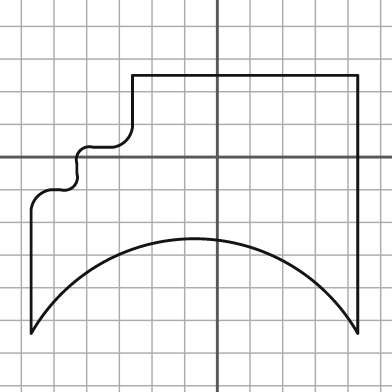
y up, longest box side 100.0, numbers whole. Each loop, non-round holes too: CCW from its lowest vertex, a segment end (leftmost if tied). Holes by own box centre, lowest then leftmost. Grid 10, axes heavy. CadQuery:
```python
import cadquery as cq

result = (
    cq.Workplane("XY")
    .moveTo(-57.0, -54.0)
    .threePointArc((-7.0, -25.0), (43.0, -54.0))
    .lineTo(43.0, 25.0)
    .lineTo(-26.0, 25.0)
    .lineTo(-26.0, 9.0)
    .threePointArc((-28.0, 5.0), (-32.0, 3.0))
    .lineTo(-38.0, 3.0)
    .threePointArc((-42.0, 2.0), (-43.0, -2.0))
    .lineTo(-43.0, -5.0)
    .threePointArc((-44.0, -9.0), (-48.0, -10.0))
    .lineTo(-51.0, -10.0)
    .threePointArc((-55.0, -12.0), (-57.0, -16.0))
    .close()
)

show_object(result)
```